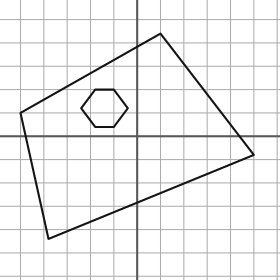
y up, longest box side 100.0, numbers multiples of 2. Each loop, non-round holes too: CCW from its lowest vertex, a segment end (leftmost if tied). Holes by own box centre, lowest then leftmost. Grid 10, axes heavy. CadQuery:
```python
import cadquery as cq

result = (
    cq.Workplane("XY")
    .moveTo(-38.0, -44.0)
    .lineTo(50.0, -8.0)
    .lineTo(10.0, 44.0)
    .lineTo(-50.0, 10.0)
    .close()
    .moveTo(-18.0, 4.0)
    .lineTo(-10.0, 4.0)
    .lineTo(-4.0, 12.0)
    .lineTo(-10.0, 20.0)
    .lineTo(-18.0, 20.0)
    .lineTo(-24.0, 12.0)
    .close()
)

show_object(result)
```